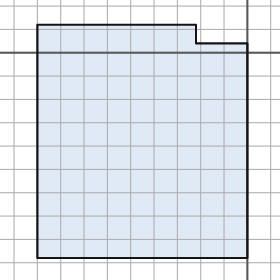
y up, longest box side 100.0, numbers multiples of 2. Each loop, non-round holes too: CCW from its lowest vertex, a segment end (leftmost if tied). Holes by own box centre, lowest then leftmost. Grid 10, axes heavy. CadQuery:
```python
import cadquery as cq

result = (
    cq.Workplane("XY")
    .moveTo(-90.0, -88.0)
    .lineTo(0.0, -88.0)
    .lineTo(0.0, 4.0)
    .lineTo(-22.0, 4.0)
    .lineTo(-22.0, 12.0)
    .lineTo(-90.0, 12.0)
    .close()
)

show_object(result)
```